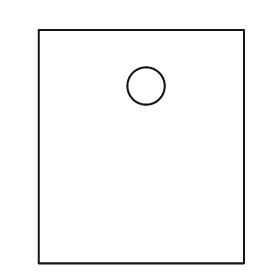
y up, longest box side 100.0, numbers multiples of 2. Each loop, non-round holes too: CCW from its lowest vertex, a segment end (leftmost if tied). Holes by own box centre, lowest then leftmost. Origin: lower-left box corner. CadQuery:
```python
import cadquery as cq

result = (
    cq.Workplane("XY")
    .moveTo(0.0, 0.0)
    .lineTo(88.0, 0.0)
    .lineTo(88.0, 100.0)
    .lineTo(0.0, 100.0)
    .close()
    .moveTo(46.0, 76.0)
    .circle(8.0)
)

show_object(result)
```